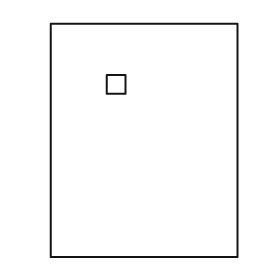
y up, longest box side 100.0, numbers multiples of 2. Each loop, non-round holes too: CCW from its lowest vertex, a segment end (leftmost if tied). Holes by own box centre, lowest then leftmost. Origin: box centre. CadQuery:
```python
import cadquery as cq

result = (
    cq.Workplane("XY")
    .moveTo(-40.0, -50.0)
    .lineTo(40.0, -50.0)
    .lineTo(40.0, 50.0)
    .lineTo(-40.0, 50.0)
    .close()
    .moveTo(-16.0, 20.0)
    .lineTo(-8.0, 20.0)
    .lineTo(-8.0, 28.0)
    .lineTo(-16.0, 28.0)
    .close()
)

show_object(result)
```